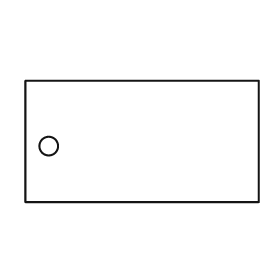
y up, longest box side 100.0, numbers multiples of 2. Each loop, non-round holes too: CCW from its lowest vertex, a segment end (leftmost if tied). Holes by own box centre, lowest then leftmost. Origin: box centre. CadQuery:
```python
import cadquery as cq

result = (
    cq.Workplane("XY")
    .moveTo(-50.0, -26.0)
    .lineTo(50.0, -26.0)
    .lineTo(50.0, 26.0)
    .lineTo(-50.0, 26.0)
    .close()
    .moveTo(-40.0, -2.0)
    .circle(4.0)
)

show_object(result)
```